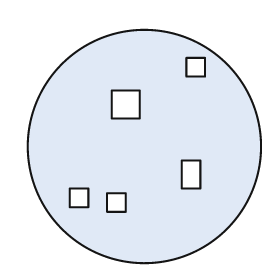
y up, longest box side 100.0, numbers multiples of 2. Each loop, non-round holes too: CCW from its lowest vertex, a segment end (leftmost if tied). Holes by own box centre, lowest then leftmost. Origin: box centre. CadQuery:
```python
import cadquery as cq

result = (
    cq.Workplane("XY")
    .moveTo(0.0, 0.0)
    .circle(50.0)
    .moveTo(-16.0, -28.0)
    .lineTo(-8.0, -28.0)
    .lineTo(-8.0, -20.0)
    .lineTo(-16.0, -20.0)
    .close()
    .moveTo(-32.0, -26.0)
    .lineTo(-24.0, -26.0)
    .lineTo(-24.0, -18.0)
    .lineTo(-32.0, -18.0)
    .close()
    .moveTo(16.0, -18.0)
    .lineTo(24.0, -18.0)
    .lineTo(24.0, -6.0)
    .lineTo(16.0, -6.0)
    .close()
    .moveTo(-14.0, 12.0)
    .lineTo(-2.0, 12.0)
    .lineTo(-2.0, 24.0)
    .lineTo(-14.0, 24.0)
    .close()
    .moveTo(18.0, 30.0)
    .lineTo(26.0, 30.0)
    .lineTo(26.0, 38.0)
    .lineTo(18.0, 38.0)
    .close()
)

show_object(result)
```